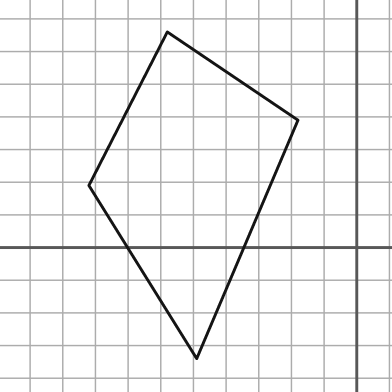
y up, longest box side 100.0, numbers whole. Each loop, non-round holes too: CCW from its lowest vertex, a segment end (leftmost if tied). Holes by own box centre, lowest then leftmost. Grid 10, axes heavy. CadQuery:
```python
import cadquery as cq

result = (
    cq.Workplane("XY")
    .moveTo(-49.0, -34.0)
    .lineTo(-18.0, 39.0)
    .lineTo(-58.0, 66.0)
    .lineTo(-82.0, 19.0)
    .close()
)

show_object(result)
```